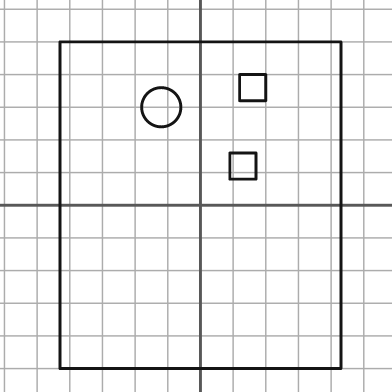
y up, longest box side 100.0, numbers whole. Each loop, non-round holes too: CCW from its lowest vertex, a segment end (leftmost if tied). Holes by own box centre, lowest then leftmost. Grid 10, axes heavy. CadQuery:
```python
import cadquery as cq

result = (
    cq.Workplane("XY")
    .moveTo(-43.0, -50.0)
    .lineTo(43.0, -50.0)
    .lineTo(43.0, 50.0)
    .lineTo(-43.0, 50.0)
    .close()
    .moveTo(9.0, 8.0)
    .lineTo(17.0, 8.0)
    .lineTo(17.0, 16.0)
    .lineTo(9.0, 16.0)
    .close()
    .moveTo(-12.0, 30.0)
    .circle(6.0)
    .moveTo(12.0, 32.0)
    .lineTo(20.0, 32.0)
    .lineTo(20.0, 40.0)
    .lineTo(12.0, 40.0)
    .close()
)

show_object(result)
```